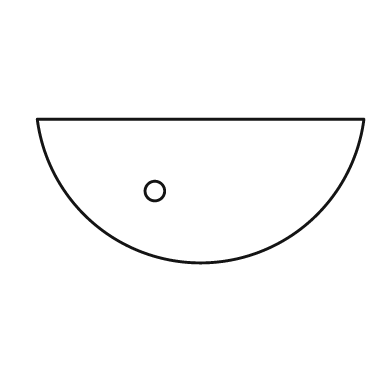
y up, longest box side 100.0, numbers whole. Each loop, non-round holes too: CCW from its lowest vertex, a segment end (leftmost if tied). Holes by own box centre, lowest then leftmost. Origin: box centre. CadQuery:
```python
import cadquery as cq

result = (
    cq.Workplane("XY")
    .moveTo(-50.0, 22.0)
    .threePointArc((0.0, -22.0), (50.0, 22.0))
    .close()
    .moveTo(-14.0, 0.0)
    .circle(3.0)
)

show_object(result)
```